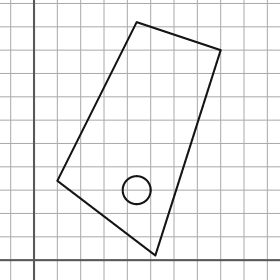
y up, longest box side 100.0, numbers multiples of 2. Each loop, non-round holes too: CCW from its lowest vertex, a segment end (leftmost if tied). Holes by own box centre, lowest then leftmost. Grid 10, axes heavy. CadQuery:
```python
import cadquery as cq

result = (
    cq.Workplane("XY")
    .moveTo(52.0, 2.0)
    .lineTo(80.0, 90.0)
    .lineTo(44.0, 102.0)
    .lineTo(10.0, 34.0)
    .close()
    .moveTo(44.0, 30.0)
    .circle(6.0)
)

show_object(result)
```